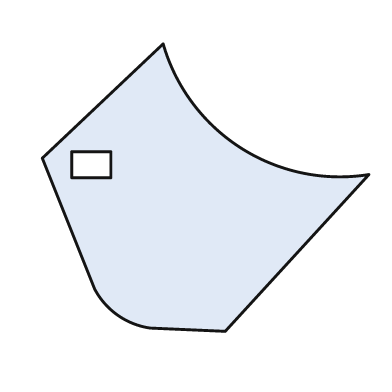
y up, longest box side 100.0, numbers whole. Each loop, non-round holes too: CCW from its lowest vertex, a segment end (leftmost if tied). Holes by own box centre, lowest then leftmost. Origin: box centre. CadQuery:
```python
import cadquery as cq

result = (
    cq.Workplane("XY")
    .moveTo(6.0, -44.0)
    .lineTo(50.0, 4.0)
    .threePointArc((11.0, 12.0), (-13.0, 44.0))
    .lineTo(-50.0, 9.0)
    .lineTo(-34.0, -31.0)
    .threePointArc((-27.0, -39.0), (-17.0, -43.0))
    .close()
    .moveTo(-41.0, 3.0)
    .lineTo(-29.0, 3.0)
    .lineTo(-29.0, 11.0)
    .lineTo(-41.0, 11.0)
    .close()
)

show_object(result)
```